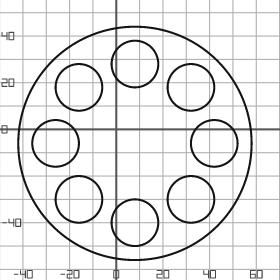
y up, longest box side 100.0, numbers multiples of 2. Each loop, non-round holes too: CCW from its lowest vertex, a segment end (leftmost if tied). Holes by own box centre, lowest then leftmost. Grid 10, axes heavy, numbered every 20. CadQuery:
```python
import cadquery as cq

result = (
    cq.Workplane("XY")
    .moveTo(8.0, -6.0)
    .circle(50.0)
    .moveTo(8.0, -40.0)
    .circle(10.0)
    .moveTo(-16.0, -30.0)
    .circle(10.0)
    .moveTo(32.0, -30.0)
    .circle(10.0)
    .moveTo(-26.0, -6.0)
    .circle(10.0)
    .moveTo(42.0, -6.0)
    .circle(10.0)
    .moveTo(-16.0, 18.0)
    .circle(10.0)
    .moveTo(32.0, 18.0)
    .circle(10.0)
    .moveTo(8.0, 28.0)
    .circle(10.0)
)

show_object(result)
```